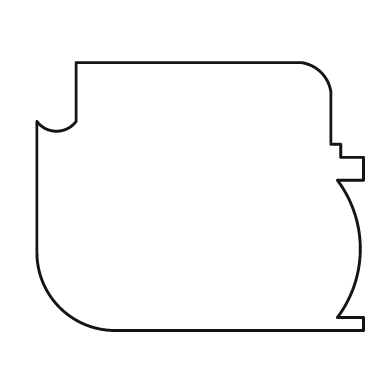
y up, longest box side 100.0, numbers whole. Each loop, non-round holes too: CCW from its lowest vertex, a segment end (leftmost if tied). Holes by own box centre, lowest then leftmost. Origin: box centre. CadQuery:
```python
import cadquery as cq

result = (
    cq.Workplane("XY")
    .moveTo(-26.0, -41.0)
    .lineTo(50.0, -41.0)
    .lineTo(50.0, -37.0)
    .lineTo(42.0, -37.0)
    .threePointArc((49.0, -16.0), (42.0, 5.0))
    .lineTo(50.0, 5.0)
    .lineTo(50.0, 12.0)
    .lineTo(43.0, 12.0)
    .lineTo(43.0, 16.0)
    .lineTo(40.0, 16.0)
    .lineTo(40.0, 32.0)
    .threePointArc((37.0, 38.0), (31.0, 41.0))
    .lineTo(-38.0, 41.0)
    .lineTo(-38.0, 23.0)
    .threePointArc((-44.0, 20.0), (-50.0, 23.0))
    .lineTo(-50.0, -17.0)
    .threePointArc((-43.0, -34.0), (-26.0, -41.0))
    .close()
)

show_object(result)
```